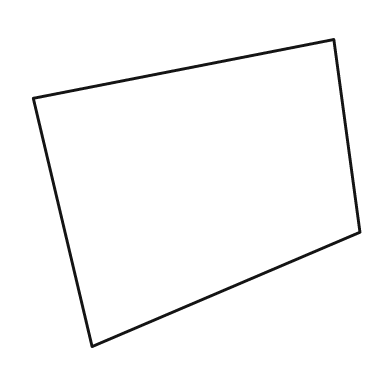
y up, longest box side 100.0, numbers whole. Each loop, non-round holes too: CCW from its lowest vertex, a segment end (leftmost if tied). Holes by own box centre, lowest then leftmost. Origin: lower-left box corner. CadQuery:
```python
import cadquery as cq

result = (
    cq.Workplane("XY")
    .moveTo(18.0, 0.0)
    .lineTo(100.0, 35.0)
    .lineTo(92.0, 94.0)
    .lineTo(0.0, 76.0)
    .close()
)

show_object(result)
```